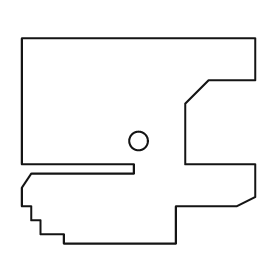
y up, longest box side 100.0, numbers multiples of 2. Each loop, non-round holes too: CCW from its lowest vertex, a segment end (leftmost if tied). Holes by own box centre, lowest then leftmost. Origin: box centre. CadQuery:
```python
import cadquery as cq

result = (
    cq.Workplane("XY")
    .moveTo(-32.0, -44.0)
    .lineTo(16.0, -44.0)
    .lineTo(16.0, -28.0)
    .lineTo(42.0, -28.0)
    .lineTo(50.0, -24.0)
    .lineTo(50.0, -10.0)
    .lineTo(20.0, -10.0)
    .lineTo(20.0, 16.0)
    .lineTo(30.0, 26.0)
    .lineTo(50.0, 26.0)
    .lineTo(50.0, 44.0)
    .lineTo(-50.0, 44.0)
    .lineTo(-50.0, -10.0)
    .lineTo(-2.0, -10.0)
    .lineTo(-2.0, -14.0)
    .lineTo(-46.0, -14.0)
    .lineTo(-50.0, -20.0)
    .lineTo(-50.0, -28.0)
    .lineTo(-46.0, -28.0)
    .lineTo(-46.0, -34.0)
    .lineTo(-42.0, -34.0)
    .lineTo(-42.0, -40.0)
    .lineTo(-32.0, -40.0)
    .close()
    .moveTo(0.0, 0.0)
    .circle(4.0)
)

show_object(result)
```